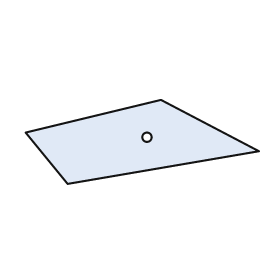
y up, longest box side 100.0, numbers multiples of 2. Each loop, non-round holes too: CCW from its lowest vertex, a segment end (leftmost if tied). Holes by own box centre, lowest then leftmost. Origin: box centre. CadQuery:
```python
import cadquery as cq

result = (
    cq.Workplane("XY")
    .moveTo(-32.0, -18.0)
    .lineTo(50.0, -4.0)
    .lineTo(8.0, 18.0)
    .lineTo(-50.0, 4.0)
    .close()
    .moveTo(2.0, 2.0)
    .circle(2.0)
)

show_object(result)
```